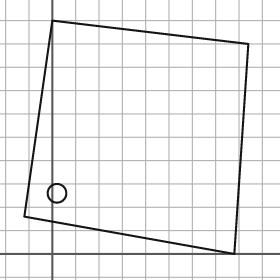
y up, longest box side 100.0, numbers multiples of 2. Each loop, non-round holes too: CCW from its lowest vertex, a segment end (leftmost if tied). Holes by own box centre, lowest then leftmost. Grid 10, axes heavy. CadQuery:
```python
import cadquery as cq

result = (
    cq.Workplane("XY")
    .moveTo(78.0, 0.0)
    .lineTo(84.0, 90.0)
    .lineTo(0.0, 100.0)
    .lineTo(-12.0, 16.0)
    .close()
    .moveTo(2.0, 26.0)
    .circle(4.0)
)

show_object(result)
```